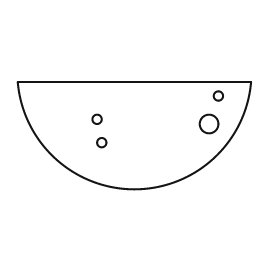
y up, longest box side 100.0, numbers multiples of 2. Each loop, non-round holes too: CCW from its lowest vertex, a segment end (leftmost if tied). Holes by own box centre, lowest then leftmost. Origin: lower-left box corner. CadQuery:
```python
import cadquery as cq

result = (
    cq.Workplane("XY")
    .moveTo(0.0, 46.0)
    .threePointArc((50.0, 0.0), (100.0, 46.0))
    .close()
    .moveTo(36.0, 20.0)
    .circle(2.0)
    .moveTo(82.0, 28.0)
    .circle(4.0)
    .moveTo(34.0, 30.0)
    .circle(2.0)
    .moveTo(86.0, 40.0)
    .circle(2.0)
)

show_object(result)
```